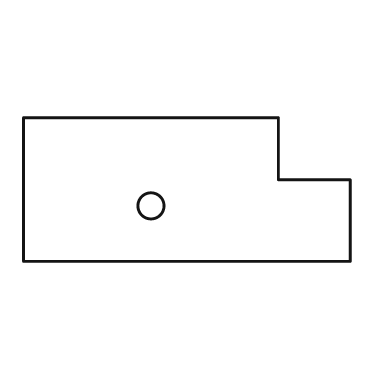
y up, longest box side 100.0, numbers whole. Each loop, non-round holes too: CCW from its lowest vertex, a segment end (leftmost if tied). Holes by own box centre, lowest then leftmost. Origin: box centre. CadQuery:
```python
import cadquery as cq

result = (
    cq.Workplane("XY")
    .moveTo(-50.0, -22.0)
    .lineTo(50.0, -22.0)
    .lineTo(50.0, 3.0)
    .lineTo(28.0, 3.0)
    .lineTo(28.0, 22.0)
    .lineTo(-50.0, 22.0)
    .close()
    .moveTo(-11.0, -5.0)
    .circle(4.0)
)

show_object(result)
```